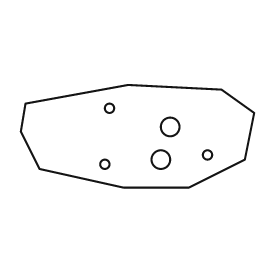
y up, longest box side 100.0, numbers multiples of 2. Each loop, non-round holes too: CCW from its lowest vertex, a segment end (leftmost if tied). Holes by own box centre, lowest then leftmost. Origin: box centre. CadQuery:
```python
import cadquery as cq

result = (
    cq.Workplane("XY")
    .moveTo(-6.0, -22.0)
    .lineTo(22.0, -22.0)
    .lineTo(46.0, -10.0)
    .lineTo(50.0, 10.0)
    .lineTo(36.0, 20.0)
    .lineTo(-4.0, 22.0)
    .lineTo(-48.0, 14.0)
    .lineTo(-50.0, 2.0)
    .lineTo(-42.0, -14.0)
    .close()
    .moveTo(-14.0, -12.0)
    .circle(2.0)
    .moveTo(10.0, -10.0)
    .circle(4.0)
    .moveTo(30.0, -8.0)
    .circle(2.0)
    .moveTo(14.0, 4.0)
    .circle(4.0)
    .moveTo(-12.0, 12.0)
    .circle(2.0)
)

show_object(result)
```